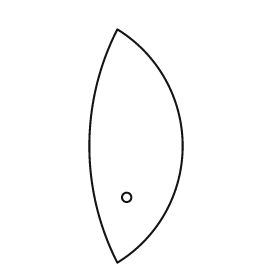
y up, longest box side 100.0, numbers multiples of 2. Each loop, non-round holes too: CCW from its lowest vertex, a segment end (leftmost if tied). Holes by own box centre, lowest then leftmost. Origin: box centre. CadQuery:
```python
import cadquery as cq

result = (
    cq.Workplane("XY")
    .moveTo(-8.0, -50.0)
    .threePointArc((20.0, 0.0), (-8.0, 50.0))
    .threePointArc((-20.0, 0.0), (-8.0, -50.0))
    .close()
    .moveTo(-4.0, -22.0)
    .circle(2.0)
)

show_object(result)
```